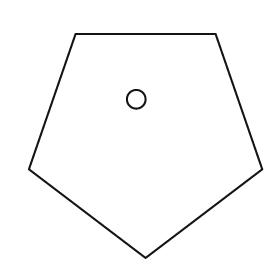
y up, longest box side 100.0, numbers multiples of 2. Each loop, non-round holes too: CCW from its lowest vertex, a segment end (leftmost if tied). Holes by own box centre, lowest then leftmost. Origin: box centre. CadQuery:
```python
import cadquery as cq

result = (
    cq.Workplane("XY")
    .moveTo(0.0, -48.0)
    .lineTo(50.0, -10.0)
    .lineTo(30.0, 48.0)
    .lineTo(-30.0, 48.0)
    .lineTo(-50.0, -10.0)
    .close()
    .moveTo(-4.0, 20.0)
    .circle(4.0)
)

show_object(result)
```